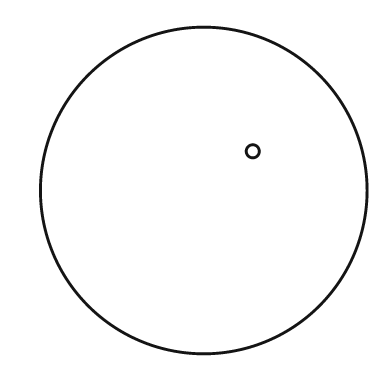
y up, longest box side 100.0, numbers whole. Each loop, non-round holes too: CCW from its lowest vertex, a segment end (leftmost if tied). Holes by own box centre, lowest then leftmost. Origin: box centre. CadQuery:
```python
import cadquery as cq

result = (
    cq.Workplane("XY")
    .moveTo(0.0, 0.0)
    .circle(50.0)
    .moveTo(15.0, 12.0)
    .circle(2.0)
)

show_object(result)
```